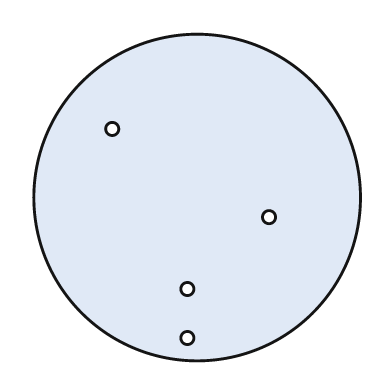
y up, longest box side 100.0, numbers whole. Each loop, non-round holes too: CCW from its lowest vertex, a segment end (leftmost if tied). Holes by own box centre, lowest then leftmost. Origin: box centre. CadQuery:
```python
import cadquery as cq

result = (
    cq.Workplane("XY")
    .moveTo(0.0, 0.0)
    .circle(50.0)
    .moveTo(-3.0, -43.0)
    .circle(2.0)
    .moveTo(-3.0, -28.0)
    .circle(2.0)
    .moveTo(22.0, -6.0)
    .circle(2.0)
    .moveTo(-26.0, 21.0)
    .circle(2.0)
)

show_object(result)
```